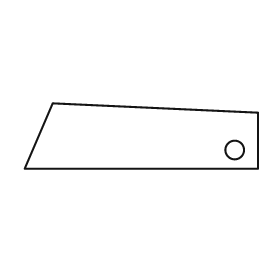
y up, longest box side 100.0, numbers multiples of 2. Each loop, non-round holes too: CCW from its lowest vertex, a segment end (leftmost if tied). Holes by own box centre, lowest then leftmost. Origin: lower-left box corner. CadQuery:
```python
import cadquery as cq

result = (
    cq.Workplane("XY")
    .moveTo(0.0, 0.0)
    .lineTo(100.0, 0.0)
    .lineTo(100.0, 24.0)
    .lineTo(12.0, 28.0)
    .close()
    .moveTo(90.0, 8.0)
    .circle(4.0)
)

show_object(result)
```